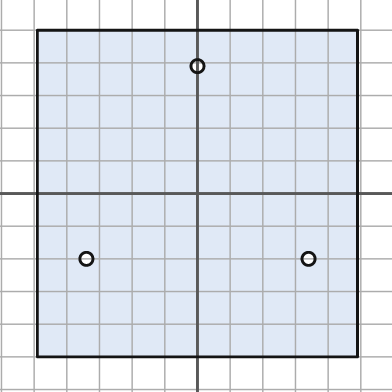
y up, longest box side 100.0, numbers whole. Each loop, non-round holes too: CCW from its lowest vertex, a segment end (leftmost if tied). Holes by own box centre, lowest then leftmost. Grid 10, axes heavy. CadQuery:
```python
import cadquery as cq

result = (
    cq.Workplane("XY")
    .moveTo(-49.0, -50.0)
    .lineTo(49.0, -50.0)
    .lineTo(49.0, 50.0)
    .lineTo(-49.0, 50.0)
    .close()
    .moveTo(-34.0, -20.0)
    .circle(2.0)
    .moveTo(34.0, -20.0)
    .circle(2.0)
    .moveTo(0.0, 39.0)
    .circle(2.0)
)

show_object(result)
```